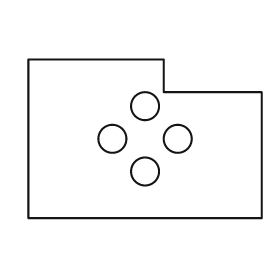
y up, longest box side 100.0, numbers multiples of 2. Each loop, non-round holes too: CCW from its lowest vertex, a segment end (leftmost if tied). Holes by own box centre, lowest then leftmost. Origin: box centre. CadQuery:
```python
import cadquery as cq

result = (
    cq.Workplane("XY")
    .moveTo(-50.0, -34.0)
    .lineTo(50.0, -34.0)
    .lineTo(50.0, 20.0)
    .lineTo(8.0, 20.0)
    .lineTo(8.0, 34.0)
    .lineTo(-50.0, 34.0)
    .close()
    .moveTo(0.0, -14.0)
    .circle(6.0)
    .moveTo(-14.0, 0.0)
    .circle(6.0)
    .moveTo(14.0, 0.0)
    .circle(6.0)
    .moveTo(0.0, 14.0)
    .circle(6.0)
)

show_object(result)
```